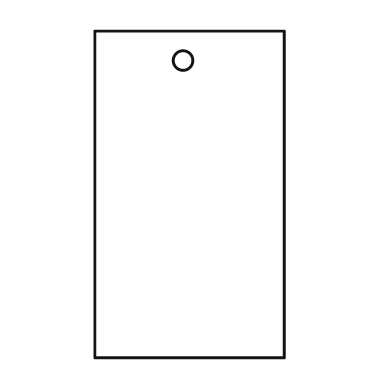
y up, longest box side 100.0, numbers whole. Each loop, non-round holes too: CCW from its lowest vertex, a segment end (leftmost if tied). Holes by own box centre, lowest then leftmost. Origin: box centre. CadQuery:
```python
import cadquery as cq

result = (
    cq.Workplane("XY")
    .moveTo(-29.0, -50.0)
    .lineTo(29.0, -50.0)
    .lineTo(29.0, 50.0)
    .lineTo(-29.0, 50.0)
    .close()
    .moveTo(-2.0, 41.0)
    .circle(3.0)
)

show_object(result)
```